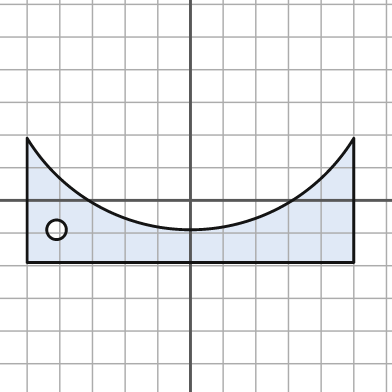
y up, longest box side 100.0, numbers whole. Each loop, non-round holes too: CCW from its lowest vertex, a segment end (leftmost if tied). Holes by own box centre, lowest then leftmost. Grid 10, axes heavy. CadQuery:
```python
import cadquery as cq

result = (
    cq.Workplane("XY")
    .moveTo(-50.0, -19.0)
    .lineTo(50.0, -19.0)
    .lineTo(50.0, 19.0)
    .threePointArc((0.0, -9.0), (-50.0, 19.0))
    .close()
    .moveTo(-41.0, -9.0)
    .circle(3.0)
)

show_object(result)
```